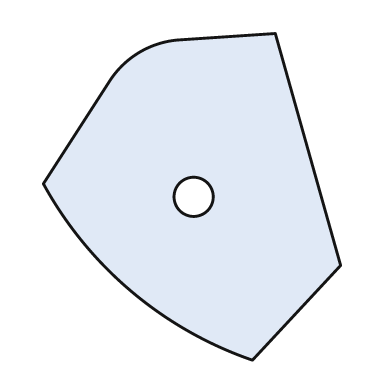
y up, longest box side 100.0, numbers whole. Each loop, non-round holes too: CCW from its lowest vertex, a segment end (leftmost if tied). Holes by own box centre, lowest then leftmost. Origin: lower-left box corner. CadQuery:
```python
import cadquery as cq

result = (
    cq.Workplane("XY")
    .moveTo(64.0, 0.0)
    .lineTo(91.0, 29.0)
    .lineTo(71.0, 100.0)
    .lineTo(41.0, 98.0)
    .threePointArc((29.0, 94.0), (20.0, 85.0))
    .lineTo(0.0, 54.0)
    .threePointArc((27.0, 21.0), (64.0, 0.0))
    .close()
    .moveTo(46.0, 50.0)
    .circle(6.0)
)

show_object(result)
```